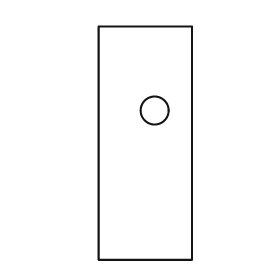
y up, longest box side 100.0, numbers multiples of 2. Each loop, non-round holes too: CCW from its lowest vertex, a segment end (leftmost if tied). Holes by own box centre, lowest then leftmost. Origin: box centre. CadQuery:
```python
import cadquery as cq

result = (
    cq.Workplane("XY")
    .moveTo(-20.0, -50.0)
    .lineTo(20.0, -50.0)
    .lineTo(20.0, 50.0)
    .lineTo(-20.0, 50.0)
    .close()
    .moveTo(4.0, 14.0)
    .circle(6.0)
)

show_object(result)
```